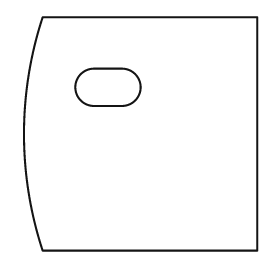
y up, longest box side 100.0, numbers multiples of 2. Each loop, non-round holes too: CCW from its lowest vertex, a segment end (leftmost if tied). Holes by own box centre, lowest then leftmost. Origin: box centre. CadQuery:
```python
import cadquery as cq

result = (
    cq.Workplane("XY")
    .moveTo(-42.0, -50.0)
    .lineTo(50.0, -50.0)
    .lineTo(50.0, 50.0)
    .lineTo(-42.0, 50.0)
    .threePointArc((-50.0, 0.0), (-42.0, -50.0))
    .close()
    .moveTo(-20.0, 12.0)
    .lineTo(-8.0, 12.0)
    .threePointArc((0.0, 20.0), (-8.0, 28.0))
    .lineTo(-20.0, 28.0)
    .threePointArc((-28.0, 20.0), (-20.0, 12.0))
    .close()
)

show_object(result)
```